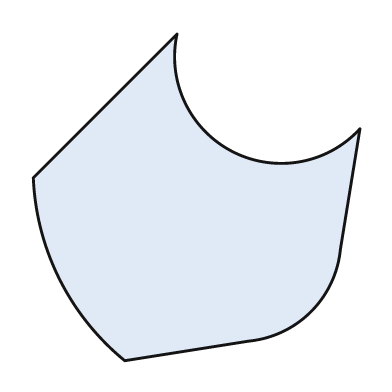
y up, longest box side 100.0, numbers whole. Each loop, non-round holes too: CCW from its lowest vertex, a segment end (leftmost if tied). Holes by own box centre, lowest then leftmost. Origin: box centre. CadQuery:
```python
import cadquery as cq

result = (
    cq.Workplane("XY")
    .moveTo(-22.0, -50.0)
    .lineTo(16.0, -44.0)
    .threePointArc((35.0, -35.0), (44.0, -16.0))
    .lineTo(50.0, 21.0)
    .threePointArc((11.0, 14.0), (-6.0, 50.0))
    .lineTo(-50.0, 6.0)
    .threePointArc((-42.0, -25.0), (-22.0, -50.0))
    .close()
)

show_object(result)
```